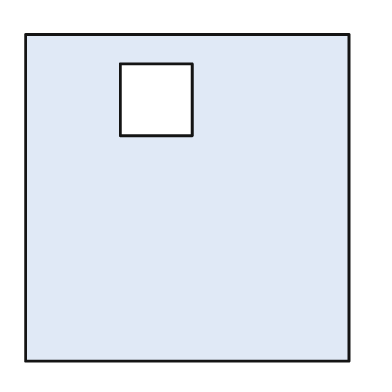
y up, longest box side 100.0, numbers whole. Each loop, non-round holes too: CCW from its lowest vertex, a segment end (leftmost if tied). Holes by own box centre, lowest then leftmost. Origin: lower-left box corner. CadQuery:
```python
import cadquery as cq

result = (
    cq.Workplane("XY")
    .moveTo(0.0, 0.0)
    .lineTo(99.0, 0.0)
    .lineTo(99.0, 100.0)
    .lineTo(0.0, 100.0)
    .close()
    .moveTo(29.0, 69.0)
    .lineTo(51.0, 69.0)
    .lineTo(51.0, 91.0)
    .lineTo(29.0, 91.0)
    .close()
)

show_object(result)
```